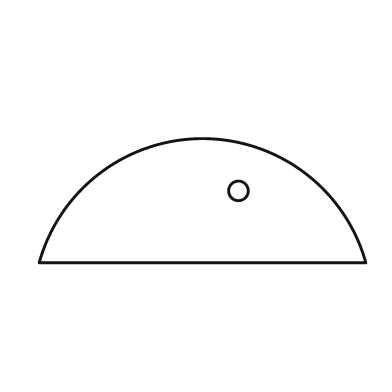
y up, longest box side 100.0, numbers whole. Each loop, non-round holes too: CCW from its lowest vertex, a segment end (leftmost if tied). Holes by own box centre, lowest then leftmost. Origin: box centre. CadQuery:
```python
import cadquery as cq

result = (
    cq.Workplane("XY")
    .moveTo(-50.0, -19.0)
    .lineTo(50.0, -19.0)
    .threePointArc((0.0, 19.0), (-50.0, -19.0))
    .close()
    .moveTo(11.0, 3.0)
    .circle(3.0)
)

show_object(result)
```